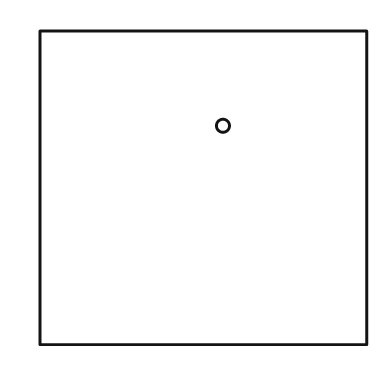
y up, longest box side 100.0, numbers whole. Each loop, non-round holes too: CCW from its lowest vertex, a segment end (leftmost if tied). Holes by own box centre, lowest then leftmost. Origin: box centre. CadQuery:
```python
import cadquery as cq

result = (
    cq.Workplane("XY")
    .moveTo(-50.0, -48.0)
    .lineTo(50.0, -48.0)
    .lineTo(50.0, 48.0)
    .lineTo(-50.0, 48.0)
    .close()
    .moveTo(6.0, 19.0)
    .circle(2.0)
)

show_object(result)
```